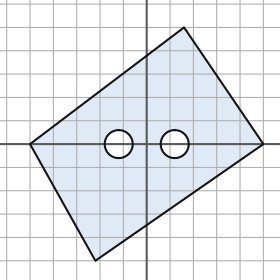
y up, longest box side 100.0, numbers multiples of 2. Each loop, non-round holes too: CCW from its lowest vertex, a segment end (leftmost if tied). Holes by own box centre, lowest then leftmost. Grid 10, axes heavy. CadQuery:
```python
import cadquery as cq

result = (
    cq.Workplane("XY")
    .moveTo(-22.0, -50.0)
    .lineTo(50.0, 0.0)
    .lineTo(16.0, 50.0)
    .lineTo(-50.0, 0.0)
    .close()
    .moveTo(-12.0, 0.0)
    .circle(6.0)
    .moveTo(12.0, 0.0)
    .circle(6.0)
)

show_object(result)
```